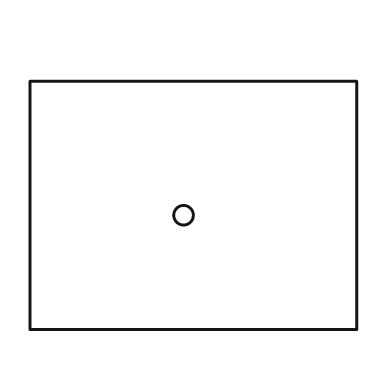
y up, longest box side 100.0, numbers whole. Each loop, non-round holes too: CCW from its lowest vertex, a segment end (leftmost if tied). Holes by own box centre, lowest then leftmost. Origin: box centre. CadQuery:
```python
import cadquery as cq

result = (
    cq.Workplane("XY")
    .moveTo(-50.0, -38.0)
    .lineTo(50.0, -38.0)
    .lineTo(50.0, 38.0)
    .lineTo(-50.0, 38.0)
    .close()
    .moveTo(-3.0, -3.0)
    .circle(3.0)
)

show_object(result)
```